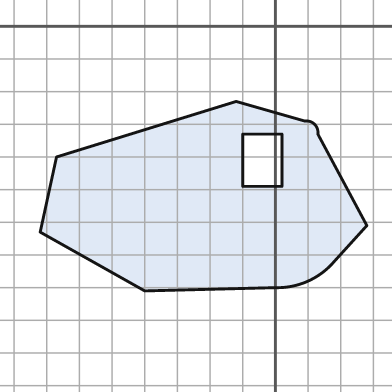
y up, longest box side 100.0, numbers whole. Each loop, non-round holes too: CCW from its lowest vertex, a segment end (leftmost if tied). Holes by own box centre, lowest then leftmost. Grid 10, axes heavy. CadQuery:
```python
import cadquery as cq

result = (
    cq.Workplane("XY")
    .moveTo(-40.0, -81.0)
    .lineTo(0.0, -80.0)
    .threePointArc((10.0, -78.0), (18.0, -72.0))
    .lineTo(28.0, -61.0)
    .lineTo(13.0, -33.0)
    .threePointArc((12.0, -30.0), (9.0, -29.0))
    .lineTo(-12.0, -23.0)
    .lineTo(-67.0, -40.0)
    .lineTo(-72.0, -63.0)
    .close()
    .moveTo(-10.0, -49.0)
    .lineTo(2.0, -49.0)
    .lineTo(2.0, -33.0)
    .lineTo(-10.0, -33.0)
    .close()
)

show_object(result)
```